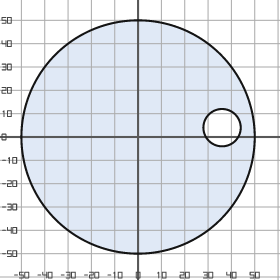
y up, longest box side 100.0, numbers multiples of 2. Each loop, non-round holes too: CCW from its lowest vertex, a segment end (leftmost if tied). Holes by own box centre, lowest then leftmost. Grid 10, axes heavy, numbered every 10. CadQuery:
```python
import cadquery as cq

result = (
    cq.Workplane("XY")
    .moveTo(0.0, 0.0)
    .circle(50.0)
    .moveTo(36.0, 4.0)
    .circle(8.0)
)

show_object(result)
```